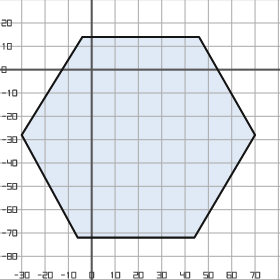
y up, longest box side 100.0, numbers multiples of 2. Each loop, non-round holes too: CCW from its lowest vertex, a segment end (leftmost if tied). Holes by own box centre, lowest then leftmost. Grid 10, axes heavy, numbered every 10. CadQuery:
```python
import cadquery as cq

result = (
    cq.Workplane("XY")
    .moveTo(-6.0, -72.0)
    .lineTo(44.0, -72.0)
    .lineTo(70.0, -28.0)
    .lineTo(46.0, 14.0)
    .lineTo(-4.0, 14.0)
    .lineTo(-30.0, -28.0)
    .close()
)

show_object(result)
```